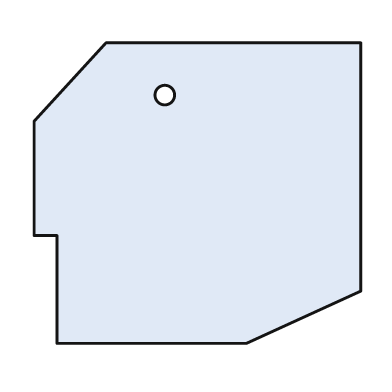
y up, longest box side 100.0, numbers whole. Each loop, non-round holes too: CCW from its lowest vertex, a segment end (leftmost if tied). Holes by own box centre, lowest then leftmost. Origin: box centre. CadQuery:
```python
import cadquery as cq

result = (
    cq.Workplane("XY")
    .moveTo(-43.0, -46.0)
    .lineTo(15.0, -46.0)
    .lineTo(50.0, -30.0)
    .lineTo(50.0, 46.0)
    .lineTo(-28.0, 46.0)
    .lineTo(-50.0, 22.0)
    .lineTo(-50.0, -13.0)
    .lineTo(-43.0, -13.0)
    .close()
    .moveTo(-10.0, 30.0)
    .circle(3.0)
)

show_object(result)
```